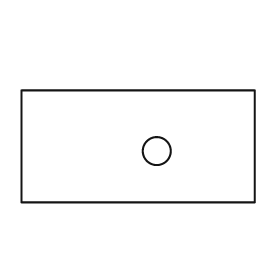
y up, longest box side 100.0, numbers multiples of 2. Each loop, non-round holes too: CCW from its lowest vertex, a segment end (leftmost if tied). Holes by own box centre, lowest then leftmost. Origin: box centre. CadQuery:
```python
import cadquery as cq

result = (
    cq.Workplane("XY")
    .moveTo(-50.0, -24.0)
    .lineTo(50.0, -24.0)
    .lineTo(50.0, 24.0)
    .lineTo(-50.0, 24.0)
    .close()
    .moveTo(8.0, -2.0)
    .circle(6.0)
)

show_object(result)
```